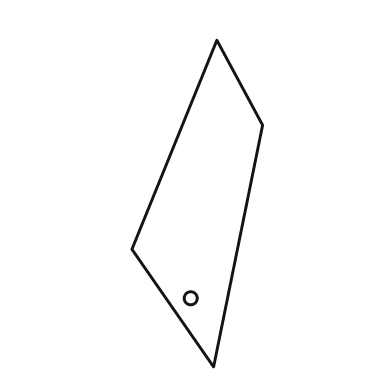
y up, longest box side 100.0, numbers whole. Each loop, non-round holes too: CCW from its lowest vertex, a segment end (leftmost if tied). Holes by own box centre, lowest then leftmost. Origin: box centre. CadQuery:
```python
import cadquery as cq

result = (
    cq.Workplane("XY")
    .moveTo(5.0, -50.0)
    .lineTo(20.0, 24.0)
    .lineTo(6.0, 50.0)
    .lineTo(-20.0, -14.0)
    .close()
    .moveTo(-2.0, -29.0)
    .circle(2.0)
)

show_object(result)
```